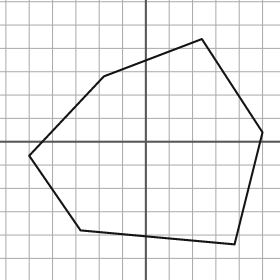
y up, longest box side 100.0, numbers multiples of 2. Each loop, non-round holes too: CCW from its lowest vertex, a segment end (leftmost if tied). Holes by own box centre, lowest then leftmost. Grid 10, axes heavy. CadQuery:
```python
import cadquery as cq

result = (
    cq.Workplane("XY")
    .moveTo(38.0, -44.0)
    .lineTo(50.0, 4.0)
    .lineTo(24.0, 44.0)
    .lineTo(-18.0, 28.0)
    .lineTo(-50.0, -6.0)
    .lineTo(-28.0, -38.0)
    .close()
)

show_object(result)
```